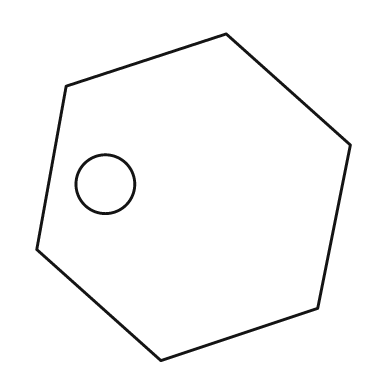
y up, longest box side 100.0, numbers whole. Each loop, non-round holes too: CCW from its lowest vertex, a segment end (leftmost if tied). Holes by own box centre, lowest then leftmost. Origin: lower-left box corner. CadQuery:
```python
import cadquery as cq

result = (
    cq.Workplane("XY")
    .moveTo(38.0, 0.0)
    .lineTo(86.0, 16.0)
    .lineTo(96.0, 66.0)
    .lineTo(58.0, 100.0)
    .lineTo(9.0, 84.0)
    .lineTo(0.0, 34.0)
    .close()
    .moveTo(21.0, 54.0)
    .circle(9.0)
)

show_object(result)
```